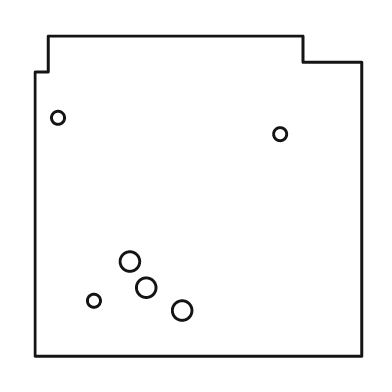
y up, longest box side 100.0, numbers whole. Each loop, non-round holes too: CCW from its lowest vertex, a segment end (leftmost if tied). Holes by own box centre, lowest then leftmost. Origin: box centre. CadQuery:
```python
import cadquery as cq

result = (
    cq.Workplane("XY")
    .moveTo(-50.0, -49.0)
    .lineTo(50.0, -49.0)
    .lineTo(50.0, 41.0)
    .lineTo(32.0, 41.0)
    .lineTo(32.0, 49.0)
    .lineTo(-46.0, 49.0)
    .lineTo(-46.0, 38.0)
    .lineTo(-50.0, 38.0)
    .close()
    .moveTo(-5.0, -35.0)
    .circle(3.0)
    .moveTo(-32.0, -32.0)
    .circle(2.0)
    .moveTo(-16.0, -28.0)
    .circle(3.0)
    .moveTo(-21.0, -20.0)
    .circle(3.0)
    .moveTo(25.0, 19.0)
    .circle(2.0)
    .moveTo(-43.0, 24.0)
    .circle(2.0)
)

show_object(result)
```